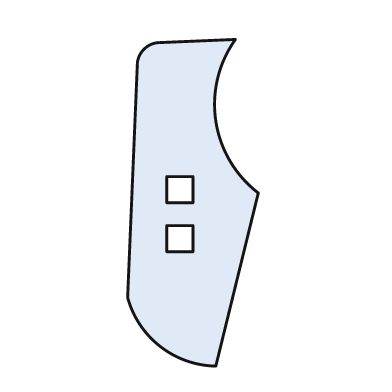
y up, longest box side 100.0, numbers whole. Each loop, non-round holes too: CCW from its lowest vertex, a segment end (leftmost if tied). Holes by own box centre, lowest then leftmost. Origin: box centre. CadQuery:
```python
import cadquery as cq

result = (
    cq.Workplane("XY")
    .moveTo(7.0, -50.0)
    .lineTo(20.0, 3.0)
    .threePointArc((7.0, 25.0), (13.0, 50.0))
    .lineTo(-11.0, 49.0)
    .threePointArc((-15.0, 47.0), (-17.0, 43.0))
    .lineTo(-20.0, -29.0)
    .threePointArc((-10.0, -44.0), (7.0, -50.0))
    .close()
    .moveTo(-8.0, -15.0)
    .lineTo(0.0, -15.0)
    .lineTo(0.0, -7.0)
    .lineTo(-8.0, -7.0)
    .close()
    .moveTo(-8.0, 0.0)
    .lineTo(0.0, 0.0)
    .lineTo(0.0, 8.0)
    .lineTo(-8.0, 8.0)
    .close()
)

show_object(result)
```